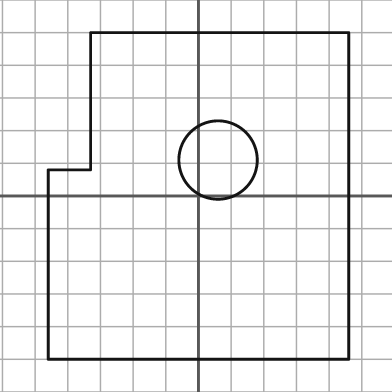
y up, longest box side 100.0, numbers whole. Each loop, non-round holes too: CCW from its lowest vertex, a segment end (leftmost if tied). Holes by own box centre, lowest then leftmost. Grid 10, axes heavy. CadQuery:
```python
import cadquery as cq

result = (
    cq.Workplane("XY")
    .moveTo(-46.0, -50.0)
    .lineTo(46.0, -50.0)
    .lineTo(46.0, 50.0)
    .lineTo(-33.0, 50.0)
    .lineTo(-33.0, 8.0)
    .lineTo(-46.0, 8.0)
    .close()
    .moveTo(6.0, 11.0)
    .circle(12.0)
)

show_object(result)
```